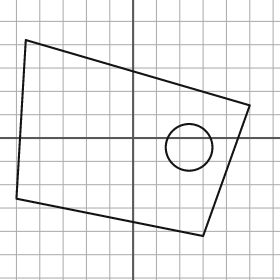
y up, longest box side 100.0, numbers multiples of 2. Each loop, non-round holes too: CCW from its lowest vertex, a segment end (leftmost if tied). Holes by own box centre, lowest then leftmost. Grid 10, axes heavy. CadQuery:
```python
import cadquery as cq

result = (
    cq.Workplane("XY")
    .moveTo(30.0, -42.0)
    .lineTo(50.0, 14.0)
    .lineTo(-46.0, 42.0)
    .lineTo(-50.0, -26.0)
    .close()
    .moveTo(24.0, -4.0)
    .circle(10.0)
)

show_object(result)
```